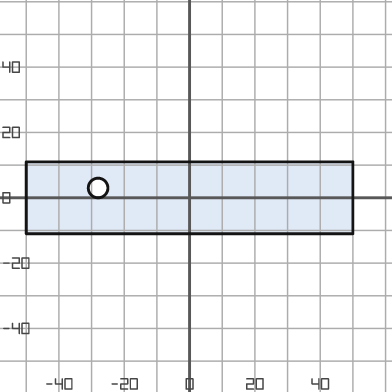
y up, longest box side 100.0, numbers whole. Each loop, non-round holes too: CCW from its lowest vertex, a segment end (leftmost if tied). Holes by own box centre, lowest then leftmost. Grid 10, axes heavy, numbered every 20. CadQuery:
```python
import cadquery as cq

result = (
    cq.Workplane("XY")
    .moveTo(-50.0, -11.0)
    .lineTo(50.0, -11.0)
    .lineTo(50.0, 11.0)
    .lineTo(-50.0, 11.0)
    .close()
    .moveTo(-28.0, 3.0)
    .circle(3.0)
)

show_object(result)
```